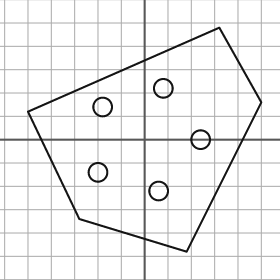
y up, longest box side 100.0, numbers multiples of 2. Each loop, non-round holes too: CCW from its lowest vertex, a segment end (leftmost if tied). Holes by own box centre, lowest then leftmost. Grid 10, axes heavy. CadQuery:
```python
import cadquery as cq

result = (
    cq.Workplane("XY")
    .moveTo(18.0, -48.0)
    .lineTo(50.0, 16.0)
    .lineTo(32.0, 48.0)
    .lineTo(-50.0, 12.0)
    .lineTo(-28.0, -34.0)
    .close()
    .moveTo(6.0, -22.0)
    .circle(4.0)
    .moveTo(-20.0, -14.0)
    .circle(4.0)
    .moveTo(24.0, 0.0)
    .circle(4.0)
    .moveTo(-18.0, 14.0)
    .circle(4.0)
    .moveTo(8.0, 22.0)
    .circle(4.0)
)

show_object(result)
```